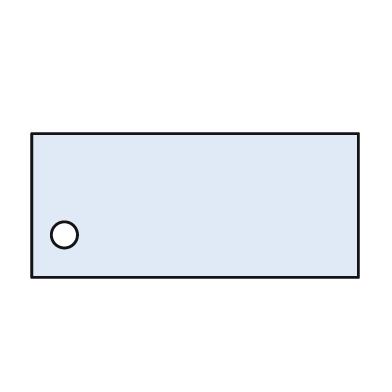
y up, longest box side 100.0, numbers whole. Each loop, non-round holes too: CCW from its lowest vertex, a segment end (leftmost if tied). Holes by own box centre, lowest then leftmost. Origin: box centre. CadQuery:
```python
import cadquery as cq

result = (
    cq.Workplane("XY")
    .moveTo(-50.0, -22.0)
    .lineTo(50.0, -22.0)
    .lineTo(50.0, 22.0)
    .lineTo(-50.0, 22.0)
    .close()
    .moveTo(-40.0, -9.0)
    .circle(4.0)
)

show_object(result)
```